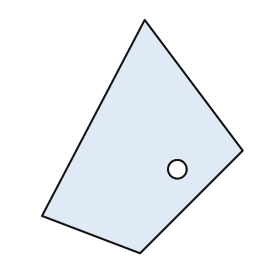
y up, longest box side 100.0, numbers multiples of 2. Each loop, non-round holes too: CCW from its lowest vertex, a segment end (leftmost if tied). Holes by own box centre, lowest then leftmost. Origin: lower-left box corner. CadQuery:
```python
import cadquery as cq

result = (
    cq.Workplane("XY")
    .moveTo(42.0, 0.0)
    .lineTo(86.0, 44.0)
    .lineTo(44.0, 100.0)
    .lineTo(0.0, 16.0)
    .close()
    .moveTo(58.0, 36.0)
    .circle(4.0)
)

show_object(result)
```